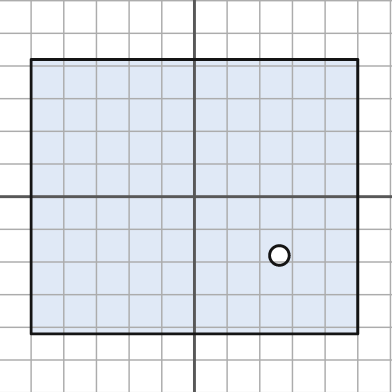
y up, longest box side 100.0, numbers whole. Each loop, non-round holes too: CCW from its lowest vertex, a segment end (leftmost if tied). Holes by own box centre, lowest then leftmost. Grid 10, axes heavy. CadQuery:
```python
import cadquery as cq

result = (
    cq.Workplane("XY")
    .moveTo(-50.0, -42.0)
    .lineTo(50.0, -42.0)
    .lineTo(50.0, 42.0)
    .lineTo(-50.0, 42.0)
    .close()
    .moveTo(26.0, -18.0)
    .circle(3.0)
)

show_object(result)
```